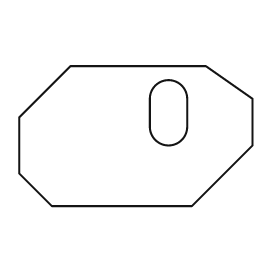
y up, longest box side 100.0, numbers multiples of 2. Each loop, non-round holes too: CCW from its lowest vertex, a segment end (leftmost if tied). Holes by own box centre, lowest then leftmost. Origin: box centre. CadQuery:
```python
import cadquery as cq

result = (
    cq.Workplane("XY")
    .moveTo(-36.0, -30.0)
    .lineTo(24.0, -30.0)
    .lineTo(50.0, -4.0)
    .lineTo(50.0, 16.0)
    .lineTo(30.0, 30.0)
    .lineTo(-28.0, 30.0)
    .lineTo(-50.0, 8.0)
    .lineTo(-50.0, -16.0)
    .close()
    .moveTo(6.0, 4.0)
    .threePointArc((14.0, -4.0), (22.0, 4.0))
    .lineTo(22.0, 16.0)
    .threePointArc((14.0, 24.0), (6.0, 16.0))
    .close()
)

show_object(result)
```